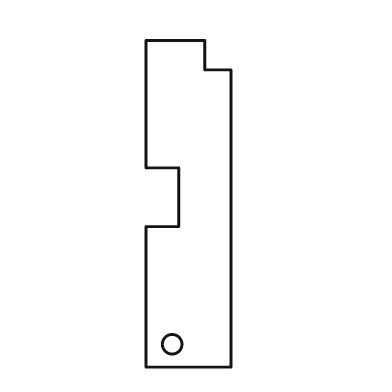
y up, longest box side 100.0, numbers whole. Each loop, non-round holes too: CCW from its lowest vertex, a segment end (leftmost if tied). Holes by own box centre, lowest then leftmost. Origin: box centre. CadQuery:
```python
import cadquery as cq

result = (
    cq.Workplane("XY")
    .moveTo(-13.0, -50.0)
    .lineTo(13.0, -50.0)
    .lineTo(13.0, 41.0)
    .lineTo(5.0, 41.0)
    .lineTo(5.0, 50.0)
    .lineTo(-13.0, 50.0)
    .lineTo(-13.0, 11.0)
    .lineTo(-3.0, 11.0)
    .lineTo(-3.0, -7.0)
    .lineTo(-13.0, -7.0)
    .close()
    .moveTo(-5.0, -43.0)
    .circle(3.0)
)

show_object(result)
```